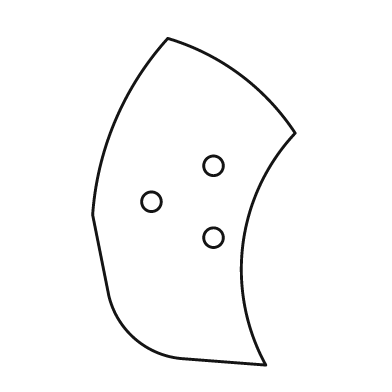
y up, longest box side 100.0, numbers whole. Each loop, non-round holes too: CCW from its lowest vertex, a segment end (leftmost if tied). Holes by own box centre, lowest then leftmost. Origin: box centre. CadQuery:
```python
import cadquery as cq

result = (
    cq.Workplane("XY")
    .moveTo(22.0, -50.0)
    .threePointArc((15.0, -13.0), (31.0, 21.0))
    .threePointArc((14.0, 39.0), (-8.0, 50.0))
    .threePointArc((-24.0, 25.0), (-31.0, -4.0))
    .lineTo(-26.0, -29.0)
    .threePointArc((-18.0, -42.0), (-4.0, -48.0))
    .close()
    .moveTo(6.0, -11.0)
    .circle(3.0)
    .moveTo(-13.0, 0.0)
    .circle(3.0)
    .moveTo(6.0, 11.0)
    .circle(3.0)
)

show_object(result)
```